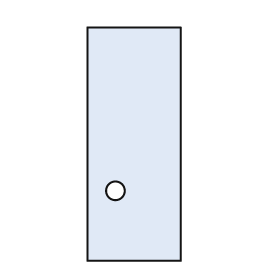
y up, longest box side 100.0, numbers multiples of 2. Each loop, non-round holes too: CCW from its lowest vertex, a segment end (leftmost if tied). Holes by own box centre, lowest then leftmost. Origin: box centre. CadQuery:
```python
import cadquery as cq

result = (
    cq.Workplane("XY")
    .moveTo(-20.0, -50.0)
    .lineTo(20.0, -50.0)
    .lineTo(20.0, 50.0)
    .lineTo(-20.0, 50.0)
    .close()
    .moveTo(-8.0, -20.0)
    .circle(4.0)
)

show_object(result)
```